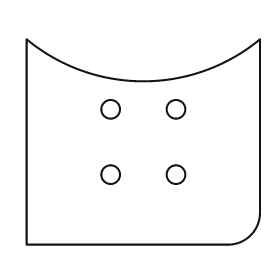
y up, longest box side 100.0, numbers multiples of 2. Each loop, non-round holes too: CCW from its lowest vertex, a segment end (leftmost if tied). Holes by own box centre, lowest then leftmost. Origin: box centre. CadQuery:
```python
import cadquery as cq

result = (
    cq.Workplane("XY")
    .moveTo(-50.0, -44.0)
    .lineTo(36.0, -44.0)
    .threePointArc((46.0, -40.0), (50.0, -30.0))
    .lineTo(50.0, 44.0)
    .threePointArc((0.0, 26.0), (-50.0, 44.0))
    .close()
    .moveTo(-14.0, -14.0)
    .circle(4.0)
    .moveTo(14.0, -14.0)
    .circle(4.0)
    .moveTo(-14.0, 14.0)
    .circle(4.0)
    .moveTo(14.0, 14.0)
    .circle(4.0)
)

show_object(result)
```